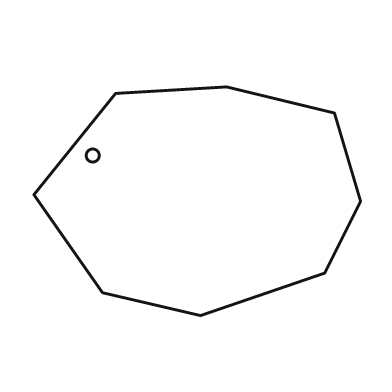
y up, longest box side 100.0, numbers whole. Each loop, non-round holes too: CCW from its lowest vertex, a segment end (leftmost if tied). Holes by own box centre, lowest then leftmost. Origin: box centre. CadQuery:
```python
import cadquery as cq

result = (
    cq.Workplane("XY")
    .moveTo(1.0, -35.0)
    .lineTo(39.0, -22.0)
    .lineTo(50.0, 0.0)
    .lineTo(42.0, 27.0)
    .lineTo(9.0, 35.0)
    .lineTo(-25.0, 33.0)
    .lineTo(-50.0, 2.0)
    .lineTo(-29.0, -28.0)
    .close()
    .moveTo(-32.0, 14.0)
    .circle(2.0)
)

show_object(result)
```